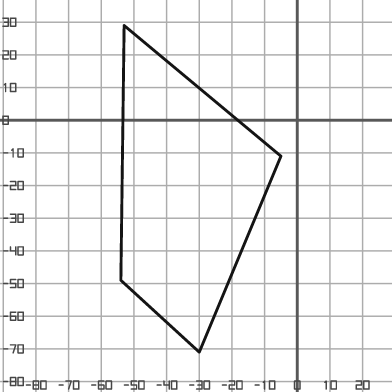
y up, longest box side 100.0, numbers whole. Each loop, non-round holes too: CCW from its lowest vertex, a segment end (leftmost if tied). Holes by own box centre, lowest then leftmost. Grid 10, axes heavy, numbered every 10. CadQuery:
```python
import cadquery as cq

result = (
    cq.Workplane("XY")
    .moveTo(-30.0, -71.0)
    .lineTo(-5.0, -11.0)
    .lineTo(-53.0, 29.0)
    .lineTo(-54.0, -49.0)
    .close()
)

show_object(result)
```